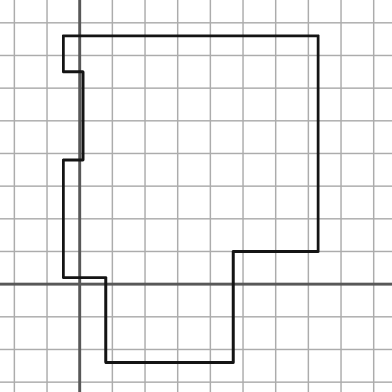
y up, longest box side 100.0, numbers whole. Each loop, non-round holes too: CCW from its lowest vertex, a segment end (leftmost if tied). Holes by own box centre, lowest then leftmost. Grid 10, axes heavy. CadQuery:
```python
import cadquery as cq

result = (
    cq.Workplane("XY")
    .moveTo(8.0, -24.0)
    .lineTo(47.0, -24.0)
    .lineTo(47.0, 10.0)
    .lineTo(73.0, 10.0)
    .lineTo(73.0, 76.0)
    .lineTo(-5.0, 76.0)
    .lineTo(-5.0, 65.0)
    .lineTo(1.0, 65.0)
    .lineTo(1.0, 38.0)
    .lineTo(-5.0, 38.0)
    .lineTo(-5.0, 2.0)
    .lineTo(8.0, 2.0)
    .close()
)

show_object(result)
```